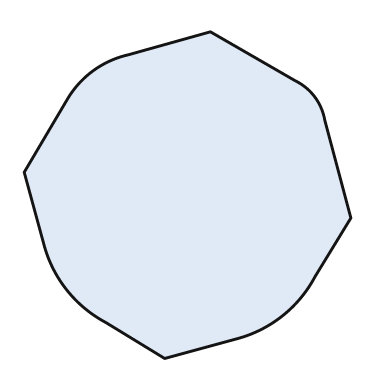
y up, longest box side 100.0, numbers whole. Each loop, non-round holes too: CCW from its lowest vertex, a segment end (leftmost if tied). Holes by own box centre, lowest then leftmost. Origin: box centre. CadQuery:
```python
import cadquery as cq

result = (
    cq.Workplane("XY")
    .moveTo(-7.0, -50.0)
    .lineTo(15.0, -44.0)
    .threePointArc((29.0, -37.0), (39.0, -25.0))
    .lineTo(50.0, -7.0)
    .lineTo(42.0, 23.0)
    .threePointArc((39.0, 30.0), (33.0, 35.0))
    .lineTo(7.0, 50.0)
    .lineTo(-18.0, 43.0)
    .threePointArc((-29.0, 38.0), (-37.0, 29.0))
    .lineTo(-50.0, 7.0)
    .lineTo(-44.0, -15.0)
    .threePointArc((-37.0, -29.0), (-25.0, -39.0))
    .close()
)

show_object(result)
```